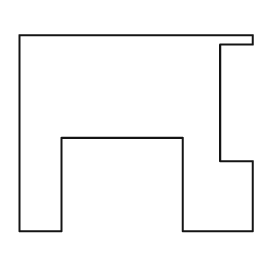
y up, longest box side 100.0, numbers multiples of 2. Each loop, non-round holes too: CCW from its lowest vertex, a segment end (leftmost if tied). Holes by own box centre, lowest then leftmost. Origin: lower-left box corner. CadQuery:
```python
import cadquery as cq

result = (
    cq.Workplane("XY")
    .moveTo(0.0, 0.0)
    .lineTo(18.0, 0.0)
    .lineTo(18.0, 40.0)
    .lineTo(70.0, 40.0)
    .lineTo(70.0, 0.0)
    .lineTo(100.0, 0.0)
    .lineTo(100.0, 30.0)
    .lineTo(86.0, 30.0)
    .lineTo(86.0, 80.0)
    .lineTo(100.0, 80.0)
    .lineTo(100.0, 84.0)
    .lineTo(0.0, 84.0)
    .close()
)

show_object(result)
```